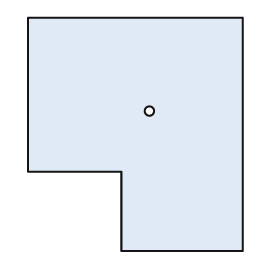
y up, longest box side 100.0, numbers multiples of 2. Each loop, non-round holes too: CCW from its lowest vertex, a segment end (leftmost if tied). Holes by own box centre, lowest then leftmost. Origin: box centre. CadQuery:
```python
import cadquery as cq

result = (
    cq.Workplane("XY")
    .moveTo(-6.0, -50.0)
    .lineTo(46.0, -50.0)
    .lineTo(46.0, 50.0)
    .lineTo(-46.0, 50.0)
    .lineTo(-46.0, -16.0)
    .lineTo(-6.0, -16.0)
    .close()
    .moveTo(6.0, 10.0)
    .circle(2.0)
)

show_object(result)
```